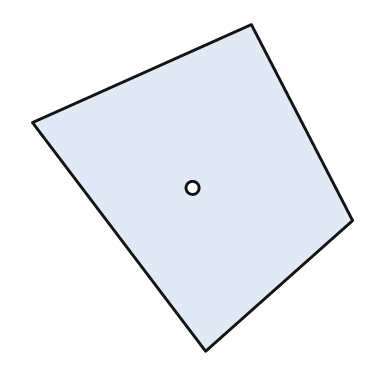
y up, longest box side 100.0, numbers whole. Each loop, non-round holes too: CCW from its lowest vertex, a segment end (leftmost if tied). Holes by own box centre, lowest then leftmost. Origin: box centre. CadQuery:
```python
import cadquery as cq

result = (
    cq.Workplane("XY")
    .moveTo(4.0, -50.0)
    .lineTo(49.0, -10.0)
    .lineTo(18.0, 50.0)
    .lineTo(-49.0, 20.0)
    .close()
    .moveTo(0.0, 0.0)
    .circle(2.0)
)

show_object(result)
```